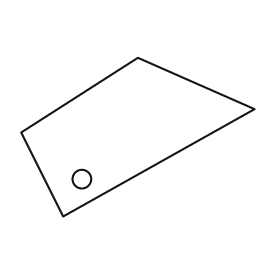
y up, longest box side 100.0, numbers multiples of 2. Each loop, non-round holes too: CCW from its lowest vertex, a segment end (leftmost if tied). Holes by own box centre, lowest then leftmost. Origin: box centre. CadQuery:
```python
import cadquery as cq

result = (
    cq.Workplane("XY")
    .moveTo(-32.0, -34.0)
    .lineTo(50.0, 12.0)
    .lineTo(0.0, 34.0)
    .lineTo(-50.0, 2.0)
    .close()
    .moveTo(-24.0, -18.0)
    .circle(4.0)
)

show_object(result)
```